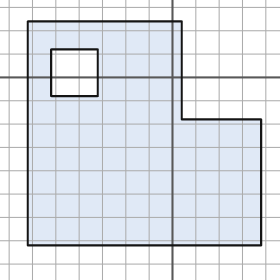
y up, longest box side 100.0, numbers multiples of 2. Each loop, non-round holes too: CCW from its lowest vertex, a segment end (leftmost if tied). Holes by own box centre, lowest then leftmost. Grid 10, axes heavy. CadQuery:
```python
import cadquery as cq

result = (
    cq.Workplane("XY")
    .moveTo(-62.0, -72.0)
    .lineTo(38.0, -72.0)
    .lineTo(38.0, -18.0)
    .lineTo(4.0, -18.0)
    .lineTo(4.0, 24.0)
    .lineTo(-62.0, 24.0)
    .close()
    .moveTo(-52.0, -8.0)
    .lineTo(-32.0, -8.0)
    .lineTo(-32.0, 12.0)
    .lineTo(-52.0, 12.0)
    .close()
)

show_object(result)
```